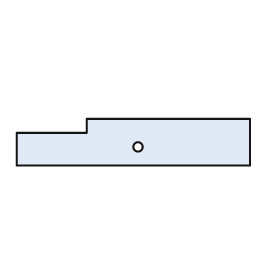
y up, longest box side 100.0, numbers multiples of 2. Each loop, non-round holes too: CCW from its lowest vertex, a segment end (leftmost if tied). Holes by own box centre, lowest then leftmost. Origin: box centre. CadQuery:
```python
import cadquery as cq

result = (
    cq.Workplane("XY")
    .moveTo(-50.0, -10.0)
    .lineTo(50.0, -10.0)
    .lineTo(50.0, 10.0)
    .lineTo(-20.0, 10.0)
    .lineTo(-20.0, 4.0)
    .lineTo(-50.0, 4.0)
    .close()
    .moveTo(2.0, -2.0)
    .circle(2.0)
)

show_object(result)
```